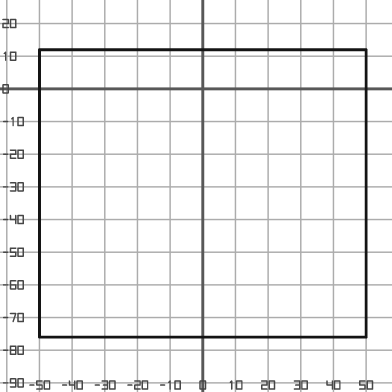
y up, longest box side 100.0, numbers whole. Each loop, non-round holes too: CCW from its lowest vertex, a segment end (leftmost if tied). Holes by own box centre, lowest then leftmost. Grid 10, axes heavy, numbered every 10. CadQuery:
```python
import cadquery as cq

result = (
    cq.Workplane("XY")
    .moveTo(-50.0, -76.0)
    .lineTo(50.0, -76.0)
    .lineTo(50.0, 12.0)
    .lineTo(-50.0, 12.0)
    .close()
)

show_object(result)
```